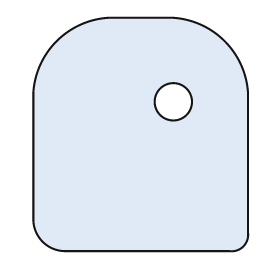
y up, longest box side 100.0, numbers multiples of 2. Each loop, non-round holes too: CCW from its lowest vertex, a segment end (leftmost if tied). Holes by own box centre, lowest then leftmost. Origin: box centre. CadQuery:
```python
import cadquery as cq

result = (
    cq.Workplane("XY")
    .moveTo(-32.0, -50.0)
    .lineTo(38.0, -50.0)
    .threePointArc((44.0, -48.0), (46.0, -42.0))
    .lineTo(46.0, 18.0)
    .threePointArc((36.0, 40.0), (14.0, 50.0))
    .lineTo(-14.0, 50.0)
    .threePointArc((-36.0, 40.0), (-46.0, 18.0))
    .lineTo(-46.0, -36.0)
    .threePointArc((-42.0, -46.0), (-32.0, -50.0))
    .close()
    .moveTo(14.0, 14.0)
    .circle(8.0)
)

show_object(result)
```